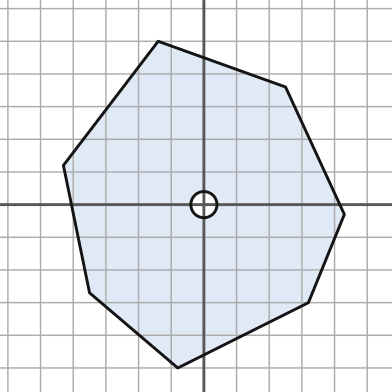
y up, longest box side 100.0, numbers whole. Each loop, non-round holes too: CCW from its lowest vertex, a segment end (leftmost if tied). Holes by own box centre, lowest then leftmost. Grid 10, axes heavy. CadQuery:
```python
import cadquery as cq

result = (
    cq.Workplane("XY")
    .moveTo(-8.0, -50.0)
    .lineTo(32.0, -30.0)
    .lineTo(43.0, -3.0)
    .lineTo(25.0, 36.0)
    .lineTo(-14.0, 50.0)
    .lineTo(-43.0, 12.0)
    .lineTo(-35.0, -27.0)
    .close()
    .moveTo(0.0, 0.0)
    .circle(4.0)
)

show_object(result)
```